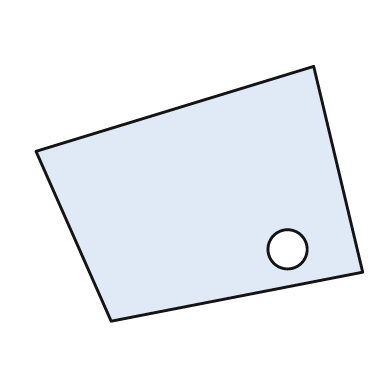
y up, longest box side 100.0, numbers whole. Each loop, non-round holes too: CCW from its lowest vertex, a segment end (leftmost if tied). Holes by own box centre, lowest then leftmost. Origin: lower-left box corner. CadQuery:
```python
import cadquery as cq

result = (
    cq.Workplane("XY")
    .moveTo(23.0, 0.0)
    .lineTo(100.0, 15.0)
    .lineTo(85.0, 78.0)
    .lineTo(0.0, 52.0)
    .close()
    .moveTo(77.0, 22.0)
    .circle(6.0)
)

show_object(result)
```